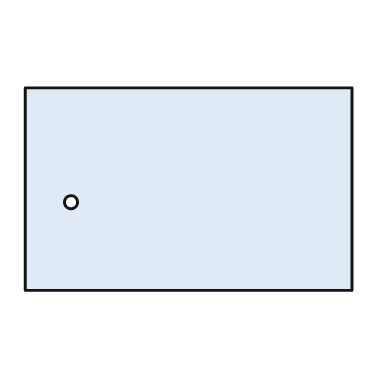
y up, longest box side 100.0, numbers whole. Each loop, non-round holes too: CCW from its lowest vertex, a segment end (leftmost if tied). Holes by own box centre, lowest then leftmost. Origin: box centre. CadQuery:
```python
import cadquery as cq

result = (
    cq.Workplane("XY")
    .moveTo(-50.0, -31.0)
    .lineTo(50.0, -31.0)
    .lineTo(50.0, 31.0)
    .lineTo(-50.0, 31.0)
    .close()
    .moveTo(-36.0, -4.0)
    .circle(2.0)
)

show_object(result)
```